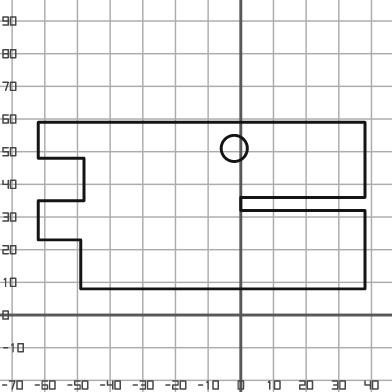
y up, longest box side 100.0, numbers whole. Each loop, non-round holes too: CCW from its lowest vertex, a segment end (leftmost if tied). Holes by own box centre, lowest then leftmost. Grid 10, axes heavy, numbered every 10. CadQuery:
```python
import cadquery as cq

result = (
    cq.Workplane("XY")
    .moveTo(-49.0, 8.0)
    .lineTo(38.0, 8.0)
    .lineTo(38.0, 32.0)
    .lineTo(0.0, 32.0)
    .lineTo(0.0, 36.0)
    .lineTo(38.0, 36.0)
    .lineTo(38.0, 59.0)
    .lineTo(-62.0, 59.0)
    .lineTo(-62.0, 48.0)
    .lineTo(-48.0, 48.0)
    .lineTo(-48.0, 35.0)
    .lineTo(-62.0, 35.0)
    .lineTo(-62.0, 23.0)
    .lineTo(-49.0, 23.0)
    .close()
    .moveTo(-2.0, 51.0)
    .circle(4.0)
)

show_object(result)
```